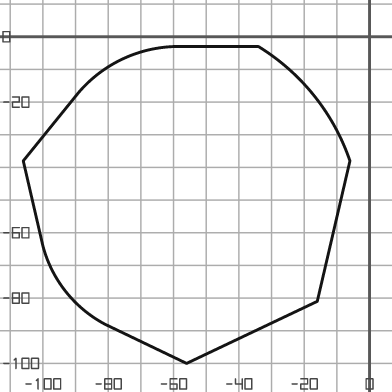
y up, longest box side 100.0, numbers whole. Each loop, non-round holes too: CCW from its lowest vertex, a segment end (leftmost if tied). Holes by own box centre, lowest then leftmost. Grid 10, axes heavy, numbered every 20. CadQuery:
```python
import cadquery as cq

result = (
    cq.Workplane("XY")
    .moveTo(-56.0, -100.0)
    .lineTo(-16.0, -81.0)
    .lineTo(-6.0, -38.0)
    .threePointArc((-17.0, -18.0), (-34.0, -3.0))
    .lineTo(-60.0, -3.0)
    .threePointArc((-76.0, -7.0), (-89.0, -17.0))
    .lineTo(-106.0, -38.0)
    .lineTo(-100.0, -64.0)
    .threePointArc((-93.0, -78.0), (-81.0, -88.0))
    .close()
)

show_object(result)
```